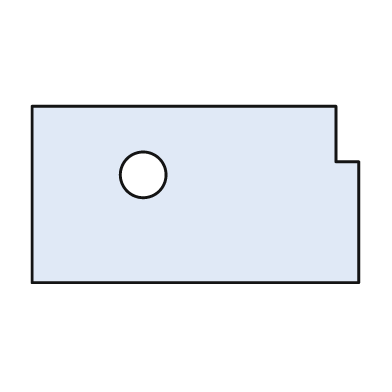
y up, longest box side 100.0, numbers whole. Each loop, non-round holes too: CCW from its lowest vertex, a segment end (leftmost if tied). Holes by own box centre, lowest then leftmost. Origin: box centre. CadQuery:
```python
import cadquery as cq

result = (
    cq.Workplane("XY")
    .moveTo(-50.0, -27.0)
    .lineTo(50.0, -27.0)
    .lineTo(50.0, 10.0)
    .lineTo(43.0, 10.0)
    .lineTo(43.0, 27.0)
    .lineTo(-50.0, 27.0)
    .close()
    .moveTo(-16.0, 6.0)
    .circle(7.0)
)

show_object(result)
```